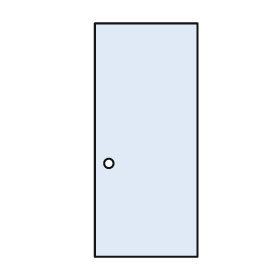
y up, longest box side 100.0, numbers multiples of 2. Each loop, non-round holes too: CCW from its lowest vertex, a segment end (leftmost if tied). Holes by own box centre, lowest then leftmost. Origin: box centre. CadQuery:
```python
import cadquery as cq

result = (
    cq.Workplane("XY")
    .moveTo(-22.0, -50.0)
    .lineTo(22.0, -50.0)
    .lineTo(22.0, 50.0)
    .lineTo(-22.0, 50.0)
    .close()
    .moveTo(-16.0, -10.0)
    .circle(2.0)
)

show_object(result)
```